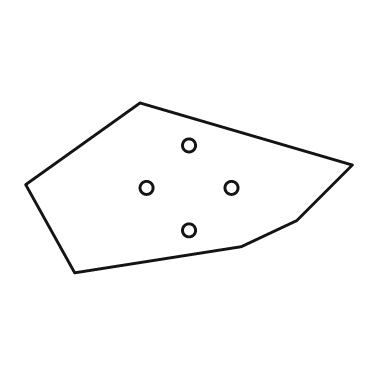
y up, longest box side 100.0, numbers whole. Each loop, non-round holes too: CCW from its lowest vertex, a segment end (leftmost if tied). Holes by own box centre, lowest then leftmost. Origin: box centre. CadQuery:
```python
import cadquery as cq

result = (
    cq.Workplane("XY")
    .moveTo(-35.0, -26.0)
    .lineTo(16.0, -18.0)
    .lineTo(33.0, -10.0)
    .lineTo(50.0, 7.0)
    .lineTo(-15.0, 26.0)
    .lineTo(-50.0, 1.0)
    .close()
    .moveTo(0.0, -13.0)
    .circle(2.0)
    .moveTo(-13.0, 0.0)
    .circle(2.0)
    .moveTo(13.0, 0.0)
    .circle(2.0)
    .moveTo(0.0, 13.0)
    .circle(2.0)
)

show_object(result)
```